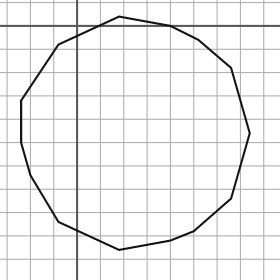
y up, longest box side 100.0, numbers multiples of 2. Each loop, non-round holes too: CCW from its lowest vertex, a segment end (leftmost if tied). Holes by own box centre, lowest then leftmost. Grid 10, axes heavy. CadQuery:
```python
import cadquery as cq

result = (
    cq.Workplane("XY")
    .moveTo(18.0, -96.0)
    .lineTo(40.0, -92.0)
    .lineTo(50.0, -88.0)
    .lineTo(66.0, -74.0)
    .lineTo(74.0, -46.0)
    .lineTo(66.0, -18.0)
    .lineTo(52.0, -6.0)
    .lineTo(40.0, 0.0)
    .lineTo(18.0, 4.0)
    .lineTo(-8.0, -8.0)
    .lineTo(-24.0, -32.0)
    .lineTo(-24.0, -50.0)
    .lineTo(-20.0, -64.0)
    .lineTo(-8.0, -84.0)
    .close()
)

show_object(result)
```